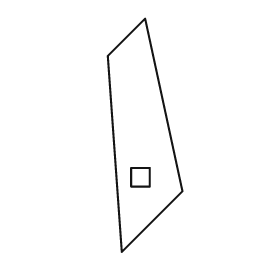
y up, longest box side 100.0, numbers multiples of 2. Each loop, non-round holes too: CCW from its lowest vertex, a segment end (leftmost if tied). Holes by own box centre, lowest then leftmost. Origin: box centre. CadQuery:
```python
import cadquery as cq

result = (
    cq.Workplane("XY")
    .moveTo(-10.0, -50.0)
    .lineTo(16.0, -24.0)
    .lineTo(0.0, 50.0)
    .lineTo(-16.0, 34.0)
    .close()
    .moveTo(-6.0, -22.0)
    .lineTo(2.0, -22.0)
    .lineTo(2.0, -14.0)
    .lineTo(-6.0, -14.0)
    .close()
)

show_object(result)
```